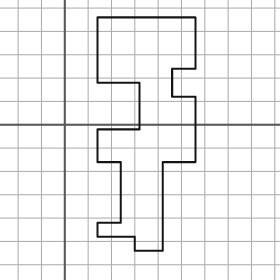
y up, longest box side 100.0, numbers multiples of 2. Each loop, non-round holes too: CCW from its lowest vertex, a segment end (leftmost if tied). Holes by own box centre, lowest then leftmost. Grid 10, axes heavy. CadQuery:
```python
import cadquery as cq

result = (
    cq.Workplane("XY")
    .moveTo(30.0, -54.0)
    .lineTo(42.0, -54.0)
    .lineTo(42.0, -16.0)
    .lineTo(56.0, -16.0)
    .lineTo(56.0, 12.0)
    .lineTo(46.0, 12.0)
    .lineTo(46.0, 24.0)
    .lineTo(56.0, 24.0)
    .lineTo(56.0, 46.0)
    .lineTo(14.0, 46.0)
    .lineTo(14.0, 18.0)
    .lineTo(32.0, 18.0)
    .lineTo(32.0, -2.0)
    .lineTo(14.0, -2.0)
    .lineTo(14.0, -16.0)
    .lineTo(24.0, -16.0)
    .lineTo(24.0, -42.0)
    .lineTo(14.0, -42.0)
    .lineTo(14.0, -48.0)
    .lineTo(30.0, -48.0)
    .close()
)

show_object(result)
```